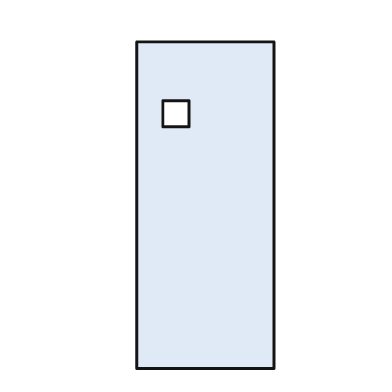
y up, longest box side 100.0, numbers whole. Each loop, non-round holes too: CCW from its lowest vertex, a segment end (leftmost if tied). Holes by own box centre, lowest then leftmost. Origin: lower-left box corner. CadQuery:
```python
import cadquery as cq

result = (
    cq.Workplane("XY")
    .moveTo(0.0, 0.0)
    .lineTo(42.0, 0.0)
    .lineTo(42.0, 100.0)
    .lineTo(0.0, 100.0)
    .close()
    .moveTo(8.0, 74.0)
    .lineTo(16.0, 74.0)
    .lineTo(16.0, 82.0)
    .lineTo(8.0, 82.0)
    .close()
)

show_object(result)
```